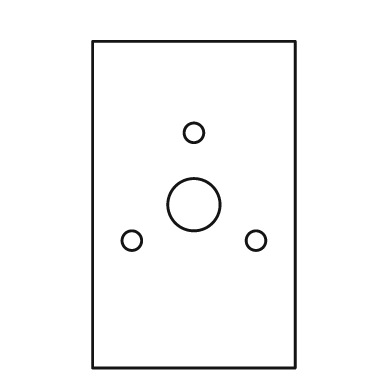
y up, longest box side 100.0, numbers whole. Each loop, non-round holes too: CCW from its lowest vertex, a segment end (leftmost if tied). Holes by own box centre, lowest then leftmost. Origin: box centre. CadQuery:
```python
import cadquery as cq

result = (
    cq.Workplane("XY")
    .moveTo(-31.0, -50.0)
    .lineTo(31.0, -50.0)
    .lineTo(31.0, 50.0)
    .lineTo(-31.0, 50.0)
    .close()
    .moveTo(-19.0, -11.0)
    .circle(3.0)
    .moveTo(19.0, -11.0)
    .circle(3.0)
    .moveTo(0.0, 0.0)
    .circle(8.0)
    .moveTo(0.0, 22.0)
    .circle(3.0)
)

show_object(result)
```